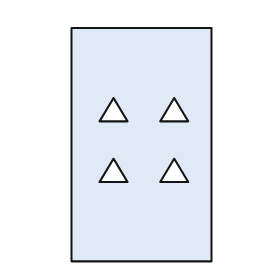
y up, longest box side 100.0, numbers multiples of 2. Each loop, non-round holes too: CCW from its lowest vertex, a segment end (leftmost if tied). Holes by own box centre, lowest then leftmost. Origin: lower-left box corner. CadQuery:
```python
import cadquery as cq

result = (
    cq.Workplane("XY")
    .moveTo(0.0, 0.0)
    .lineTo(60.0, 0.0)
    .lineTo(60.0, 100.0)
    .lineTo(0.0, 100.0)
    .close()
    .moveTo(12.0, 34.0)
    .lineTo(24.0, 34.0)
    .lineTo(18.0, 44.0)
    .close()
    .moveTo(38.0, 34.0)
    .lineTo(50.0, 34.0)
    .lineTo(44.0, 44.0)
    .close()
    .moveTo(12.0, 60.0)
    .lineTo(24.0, 60.0)
    .lineTo(18.0, 70.0)
    .close()
    .moveTo(38.0, 60.0)
    .lineTo(50.0, 60.0)
    .lineTo(44.0, 70.0)
    .close()
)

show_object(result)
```